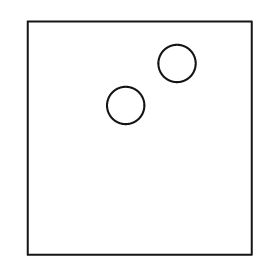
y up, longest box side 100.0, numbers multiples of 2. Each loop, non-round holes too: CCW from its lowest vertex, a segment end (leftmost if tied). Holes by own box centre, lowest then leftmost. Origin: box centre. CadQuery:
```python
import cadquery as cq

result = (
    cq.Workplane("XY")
    .moveTo(-48.0, -50.0)
    .lineTo(48.0, -50.0)
    .lineTo(48.0, 50.0)
    .lineTo(-48.0, 50.0)
    .close()
    .moveTo(-6.0, 14.0)
    .circle(8.0)
    .moveTo(16.0, 32.0)
    .circle(8.0)
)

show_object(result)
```